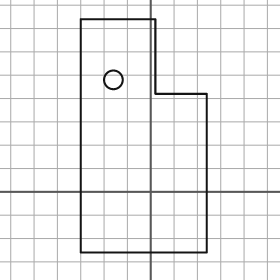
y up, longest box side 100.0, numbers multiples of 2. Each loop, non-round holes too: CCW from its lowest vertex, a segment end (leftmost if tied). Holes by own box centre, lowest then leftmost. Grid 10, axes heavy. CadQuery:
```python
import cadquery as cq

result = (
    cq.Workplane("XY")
    .moveTo(-30.0, -26.0)
    .lineTo(24.0, -26.0)
    .lineTo(24.0, 42.0)
    .lineTo(2.0, 42.0)
    .lineTo(2.0, 74.0)
    .lineTo(-30.0, 74.0)
    .close()
    .moveTo(-16.0, 48.0)
    .circle(4.0)
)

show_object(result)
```